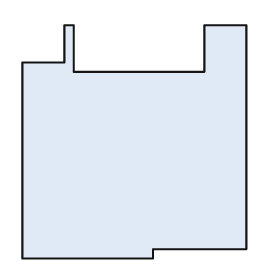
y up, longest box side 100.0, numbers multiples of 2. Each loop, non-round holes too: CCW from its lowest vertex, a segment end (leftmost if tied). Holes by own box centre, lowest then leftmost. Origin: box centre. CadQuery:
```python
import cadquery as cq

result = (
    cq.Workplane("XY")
    .moveTo(-48.0, -50.0)
    .lineTo(8.0, -50.0)
    .lineTo(8.0, -46.0)
    .lineTo(48.0, -46.0)
    .lineTo(48.0, 50.0)
    .lineTo(30.0, 50.0)
    .lineTo(30.0, 30.0)
    .lineTo(-26.0, 30.0)
    .lineTo(-26.0, 50.0)
    .lineTo(-30.0, 50.0)
    .lineTo(-30.0, 34.0)
    .lineTo(-48.0, 34.0)
    .close()
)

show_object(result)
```